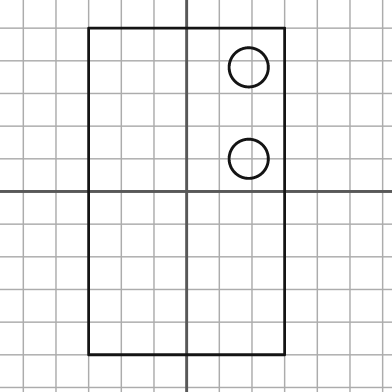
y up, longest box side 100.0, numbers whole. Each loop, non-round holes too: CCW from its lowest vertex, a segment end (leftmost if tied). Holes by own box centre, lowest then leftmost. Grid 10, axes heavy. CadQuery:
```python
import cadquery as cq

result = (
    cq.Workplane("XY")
    .moveTo(-30.0, -50.0)
    .lineTo(30.0, -50.0)
    .lineTo(30.0, 50.0)
    .lineTo(-30.0, 50.0)
    .close()
    .moveTo(19.0, 10.0)
    .circle(6.0)
    .moveTo(19.0, 38.0)
    .circle(6.0)
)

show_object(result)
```